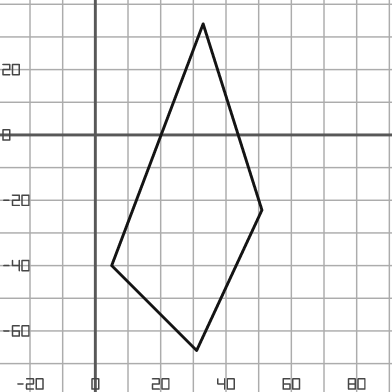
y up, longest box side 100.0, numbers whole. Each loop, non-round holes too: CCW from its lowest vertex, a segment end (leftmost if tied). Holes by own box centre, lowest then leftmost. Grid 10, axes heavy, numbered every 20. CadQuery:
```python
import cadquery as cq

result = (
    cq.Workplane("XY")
    .moveTo(31.0, -66.0)
    .lineTo(51.0, -23.0)
    .lineTo(33.0, 34.0)
    .lineTo(5.0, -40.0)
    .close()
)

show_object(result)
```